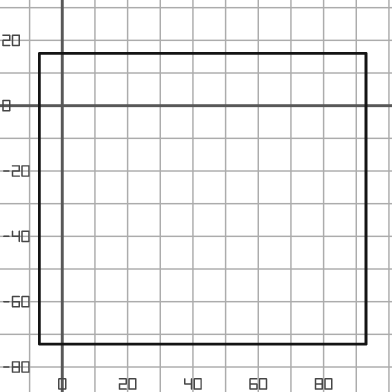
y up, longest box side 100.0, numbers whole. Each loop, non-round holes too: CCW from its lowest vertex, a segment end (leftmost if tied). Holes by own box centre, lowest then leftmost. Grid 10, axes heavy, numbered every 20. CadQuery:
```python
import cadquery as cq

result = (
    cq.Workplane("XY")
    .moveTo(-7.0, -73.0)
    .lineTo(93.0, -73.0)
    .lineTo(93.0, 16.0)
    .lineTo(-7.0, 16.0)
    .close()
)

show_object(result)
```